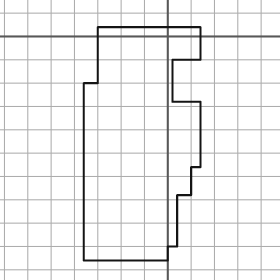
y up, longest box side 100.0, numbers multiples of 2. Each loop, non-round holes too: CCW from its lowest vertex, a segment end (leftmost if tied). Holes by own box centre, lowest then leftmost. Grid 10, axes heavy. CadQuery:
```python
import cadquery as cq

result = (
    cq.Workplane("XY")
    .moveTo(-36.0, -96.0)
    .lineTo(0.0, -96.0)
    .lineTo(0.0, -90.0)
    .lineTo(4.0, -90.0)
    .lineTo(4.0, -68.0)
    .lineTo(10.0, -68.0)
    .lineTo(10.0, -56.0)
    .lineTo(14.0, -56.0)
    .lineTo(14.0, -28.0)
    .lineTo(2.0, -28.0)
    .lineTo(2.0, -10.0)
    .lineTo(14.0, -10.0)
    .lineTo(14.0, 4.0)
    .lineTo(-30.0, 4.0)
    .lineTo(-30.0, -20.0)
    .lineTo(-36.0, -20.0)
    .close()
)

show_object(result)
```